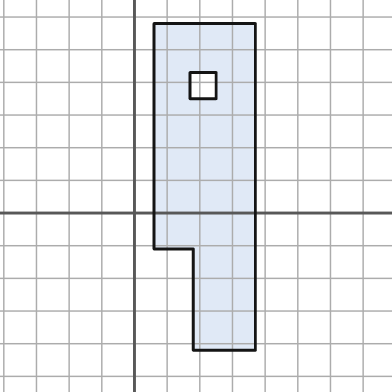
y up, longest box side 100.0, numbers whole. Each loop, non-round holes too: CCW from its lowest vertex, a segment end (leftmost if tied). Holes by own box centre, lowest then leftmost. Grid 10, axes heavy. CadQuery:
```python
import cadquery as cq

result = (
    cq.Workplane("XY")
    .moveTo(18.0, -42.0)
    .lineTo(37.0, -42.0)
    .lineTo(37.0, 58.0)
    .lineTo(6.0, 58.0)
    .lineTo(6.0, -11.0)
    .lineTo(18.0, -11.0)
    .close()
    .moveTo(17.0, 35.0)
    .lineTo(25.0, 35.0)
    .lineTo(25.0, 43.0)
    .lineTo(17.0, 43.0)
    .close()
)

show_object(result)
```